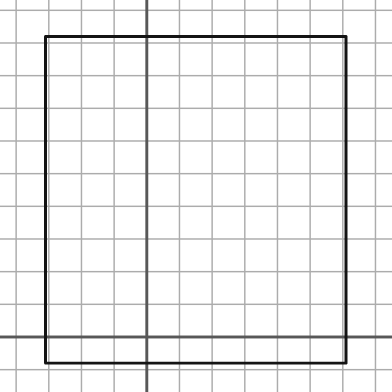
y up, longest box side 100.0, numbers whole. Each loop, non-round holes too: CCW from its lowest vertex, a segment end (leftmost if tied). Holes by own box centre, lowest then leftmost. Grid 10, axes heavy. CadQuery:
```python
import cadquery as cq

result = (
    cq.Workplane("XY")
    .moveTo(-31.0, -8.0)
    .lineTo(61.0, -8.0)
    .lineTo(61.0, 92.0)
    .lineTo(-31.0, 92.0)
    .close()
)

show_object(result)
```